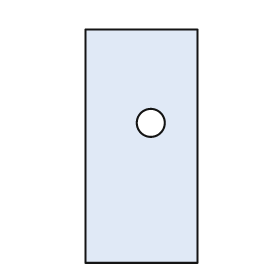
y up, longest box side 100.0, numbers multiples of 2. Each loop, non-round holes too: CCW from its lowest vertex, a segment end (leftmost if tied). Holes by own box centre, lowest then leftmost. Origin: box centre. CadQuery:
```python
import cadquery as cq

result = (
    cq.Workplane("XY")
    .moveTo(-24.0, -50.0)
    .lineTo(24.0, -50.0)
    .lineTo(24.0, 50.0)
    .lineTo(-24.0, 50.0)
    .close()
    .moveTo(4.0, 10.0)
    .circle(6.0)
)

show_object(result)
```